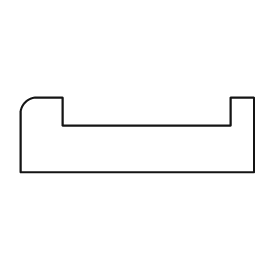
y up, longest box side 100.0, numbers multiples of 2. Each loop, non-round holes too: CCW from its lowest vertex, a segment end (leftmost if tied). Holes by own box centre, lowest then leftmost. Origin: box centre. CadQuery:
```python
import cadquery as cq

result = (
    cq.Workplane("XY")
    .moveTo(-50.0, -16.0)
    .lineTo(50.0, -16.0)
    .lineTo(50.0, 16.0)
    .lineTo(40.0, 16.0)
    .lineTo(40.0, 4.0)
    .lineTo(-32.0, 4.0)
    .lineTo(-32.0, 16.0)
    .lineTo(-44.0, 16.0)
    .threePointArc((-48.0, 14.0), (-50.0, 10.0))
    .close()
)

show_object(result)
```